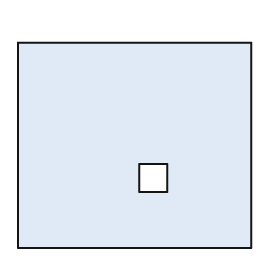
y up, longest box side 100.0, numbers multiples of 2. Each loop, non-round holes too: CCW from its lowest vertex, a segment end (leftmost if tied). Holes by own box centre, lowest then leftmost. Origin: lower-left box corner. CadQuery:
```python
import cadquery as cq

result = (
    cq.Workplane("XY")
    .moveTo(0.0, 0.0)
    .lineTo(100.0, 0.0)
    .lineTo(100.0, 88.0)
    .lineTo(0.0, 88.0)
    .close()
    .moveTo(52.0, 24.0)
    .lineTo(64.0, 24.0)
    .lineTo(64.0, 36.0)
    .lineTo(52.0, 36.0)
    .close()
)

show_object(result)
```